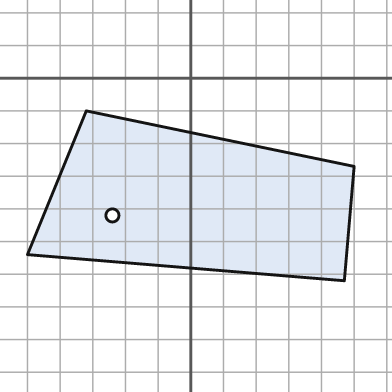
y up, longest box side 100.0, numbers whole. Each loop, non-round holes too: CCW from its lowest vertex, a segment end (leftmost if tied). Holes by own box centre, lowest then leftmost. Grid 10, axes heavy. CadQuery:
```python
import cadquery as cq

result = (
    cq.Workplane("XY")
    .moveTo(47.0, -62.0)
    .lineTo(50.0, -27.0)
    .lineTo(-32.0, -10.0)
    .lineTo(-50.0, -54.0)
    .close()
    .moveTo(-24.0, -42.0)
    .circle(2.0)
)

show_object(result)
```